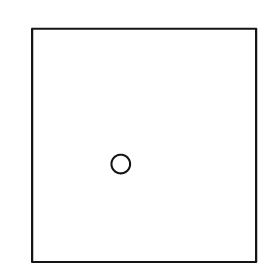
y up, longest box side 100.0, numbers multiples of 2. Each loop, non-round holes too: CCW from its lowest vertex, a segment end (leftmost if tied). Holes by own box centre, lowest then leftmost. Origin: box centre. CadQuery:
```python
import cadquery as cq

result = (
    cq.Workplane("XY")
    .moveTo(-48.0, -50.0)
    .lineTo(48.0, -50.0)
    .lineTo(48.0, 50.0)
    .lineTo(-48.0, 50.0)
    .close()
    .moveTo(-10.0, -8.0)
    .circle(4.0)
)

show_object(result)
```